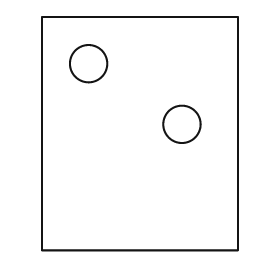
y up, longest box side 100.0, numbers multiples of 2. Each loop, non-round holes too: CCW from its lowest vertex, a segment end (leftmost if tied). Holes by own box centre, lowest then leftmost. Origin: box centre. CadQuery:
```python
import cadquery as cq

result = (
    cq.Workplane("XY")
    .moveTo(-42.0, -50.0)
    .lineTo(42.0, -50.0)
    .lineTo(42.0, 50.0)
    .lineTo(-42.0, 50.0)
    .close()
    .moveTo(18.0, 4.0)
    .circle(8.0)
    .moveTo(-22.0, 30.0)
    .circle(8.0)
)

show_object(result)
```